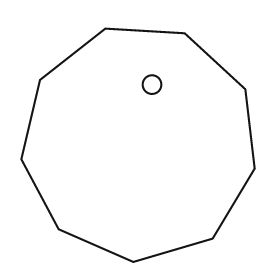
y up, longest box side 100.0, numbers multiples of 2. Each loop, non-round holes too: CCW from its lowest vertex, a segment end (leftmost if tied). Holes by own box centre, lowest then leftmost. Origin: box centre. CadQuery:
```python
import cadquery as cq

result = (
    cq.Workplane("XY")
    .moveTo(-2.0, -50.0)
    .lineTo(32.0, -40.0)
    .lineTo(50.0, -10.0)
    .lineTo(46.0, 24.0)
    .lineTo(20.0, 48.0)
    .lineTo(-14.0, 50.0)
    .lineTo(-42.0, 28.0)
    .lineTo(-50.0, -6.0)
    .lineTo(-34.0, -36.0)
    .close()
    .moveTo(6.0, 26.0)
    .circle(4.0)
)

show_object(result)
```